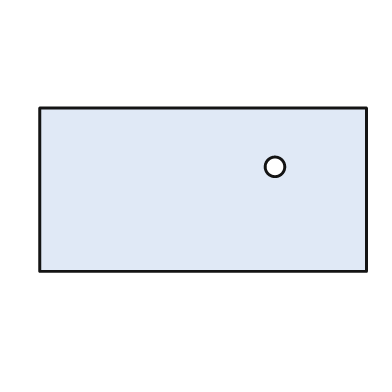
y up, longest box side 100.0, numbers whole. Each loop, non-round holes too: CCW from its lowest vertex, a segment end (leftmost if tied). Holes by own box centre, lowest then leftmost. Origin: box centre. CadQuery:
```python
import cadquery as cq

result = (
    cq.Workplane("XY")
    .moveTo(-50.0, -25.0)
    .lineTo(50.0, -25.0)
    .lineTo(50.0, 25.0)
    .lineTo(-50.0, 25.0)
    .close()
    .moveTo(22.0, 7.0)
    .circle(3.0)
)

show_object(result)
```